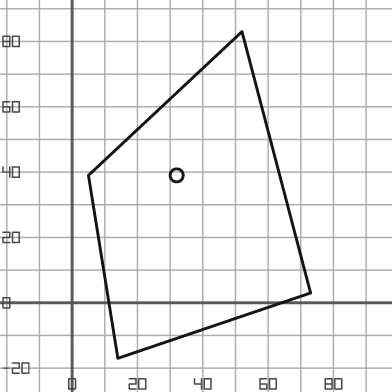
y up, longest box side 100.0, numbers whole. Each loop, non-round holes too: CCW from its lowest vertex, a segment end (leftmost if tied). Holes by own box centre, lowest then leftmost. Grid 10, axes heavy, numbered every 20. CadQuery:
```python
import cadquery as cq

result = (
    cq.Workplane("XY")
    .moveTo(14.0, -17.0)
    .lineTo(73.0, 3.0)
    .lineTo(52.0, 83.0)
    .lineTo(5.0, 39.0)
    .close()
    .moveTo(32.0, 39.0)
    .circle(2.0)
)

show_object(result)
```